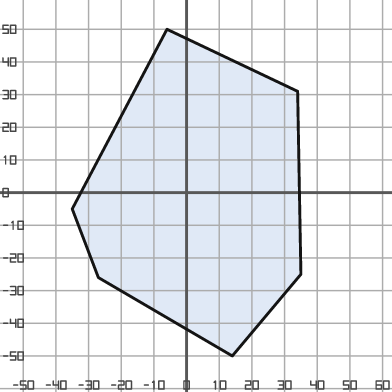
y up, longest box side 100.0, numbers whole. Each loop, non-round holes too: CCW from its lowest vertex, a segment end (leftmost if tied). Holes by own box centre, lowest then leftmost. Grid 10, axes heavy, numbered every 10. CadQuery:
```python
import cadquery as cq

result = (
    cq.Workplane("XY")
    .moveTo(14.0, -50.0)
    .lineTo(35.0, -25.0)
    .lineTo(34.0, 31.0)
    .lineTo(-6.0, 50.0)
    .lineTo(-35.0, -5.0)
    .lineTo(-27.0, -26.0)
    .close()
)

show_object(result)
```